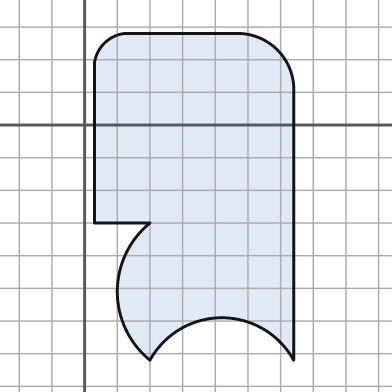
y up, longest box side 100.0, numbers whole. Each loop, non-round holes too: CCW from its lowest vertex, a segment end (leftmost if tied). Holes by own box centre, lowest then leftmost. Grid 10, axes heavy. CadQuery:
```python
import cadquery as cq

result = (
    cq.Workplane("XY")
    .moveTo(20.0, -72.0)
    .threePointArc((42.0, -59.0), (64.0, -72.0))
    .lineTo(64.0, 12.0)
    .threePointArc((59.0, 23.0), (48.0, 28.0))
    .lineTo(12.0, 28.0)
    .threePointArc((6.0, 25.0), (3.0, 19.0))
    .lineTo(3.0, -30.0)
    .lineTo(20.0, -30.0)
    .threePointArc((10.0, -51.0), (20.0, -72.0))
    .close()
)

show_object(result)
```